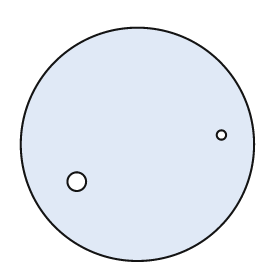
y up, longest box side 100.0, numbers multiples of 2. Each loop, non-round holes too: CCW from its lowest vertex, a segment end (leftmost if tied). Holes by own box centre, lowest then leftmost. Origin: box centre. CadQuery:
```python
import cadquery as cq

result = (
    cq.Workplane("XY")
    .moveTo(0.0, 0.0)
    .circle(50.0)
    .moveTo(-26.0, -16.0)
    .circle(4.0)
    .moveTo(36.0, 4.0)
    .circle(2.0)
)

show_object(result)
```